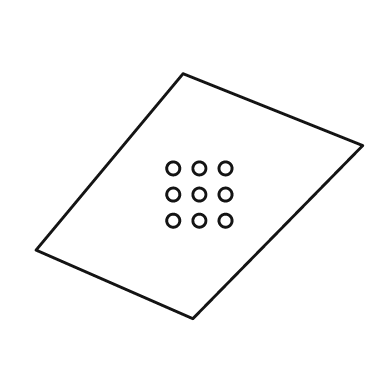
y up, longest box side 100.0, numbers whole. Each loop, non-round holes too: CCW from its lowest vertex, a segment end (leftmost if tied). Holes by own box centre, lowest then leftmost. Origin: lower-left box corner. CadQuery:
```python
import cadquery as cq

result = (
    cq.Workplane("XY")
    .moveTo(48.0, 0.0)
    .lineTo(100.0, 53.0)
    .lineTo(45.0, 75.0)
    .lineTo(0.0, 21.0)
    .close()
    .moveTo(42.0, 30.0)
    .circle(2.0)
    .moveTo(50.0, 30.0)
    .circle(2.0)
    .moveTo(58.0, 30.0)
    .circle(2.0)
    .moveTo(42.0, 38.0)
    .circle(2.0)
    .moveTo(50.0, 38.0)
    .circle(2.0)
    .moveTo(58.0, 38.0)
    .circle(2.0)
    .moveTo(42.0, 46.0)
    .circle(2.0)
    .moveTo(50.0, 46.0)
    .circle(2.0)
    .moveTo(58.0, 46.0)
    .circle(2.0)
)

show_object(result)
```